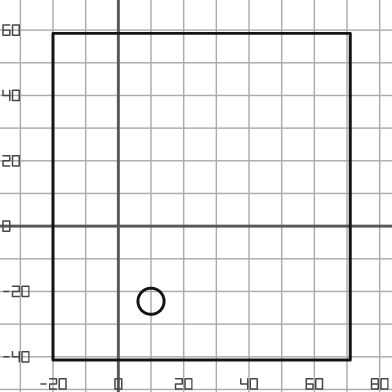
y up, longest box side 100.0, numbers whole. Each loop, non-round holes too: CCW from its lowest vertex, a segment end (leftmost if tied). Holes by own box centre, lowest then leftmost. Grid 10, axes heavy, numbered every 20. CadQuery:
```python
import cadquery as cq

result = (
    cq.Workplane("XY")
    .moveTo(-20.0, -41.0)
    .lineTo(71.0, -41.0)
    .lineTo(71.0, 59.0)
    .lineTo(-20.0, 59.0)
    .close()
    .moveTo(10.0, -23.0)
    .circle(4.0)
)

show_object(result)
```